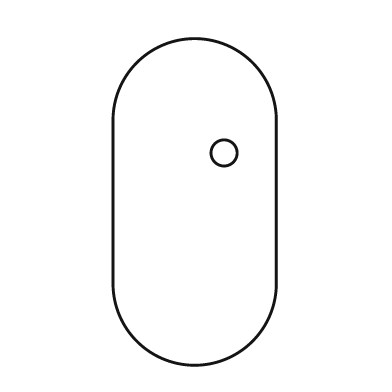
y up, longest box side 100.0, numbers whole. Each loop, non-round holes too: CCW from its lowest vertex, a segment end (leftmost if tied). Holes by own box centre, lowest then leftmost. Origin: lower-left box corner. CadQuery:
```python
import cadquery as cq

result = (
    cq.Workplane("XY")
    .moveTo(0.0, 25.0)
    .threePointArc((25.0, 0.0), (50.0, 25.0))
    .lineTo(50.0, 75.0)
    .threePointArc((25.0, 100.0), (0.0, 75.0))
    .close()
    .moveTo(34.0, 65.0)
    .circle(4.0)
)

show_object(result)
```